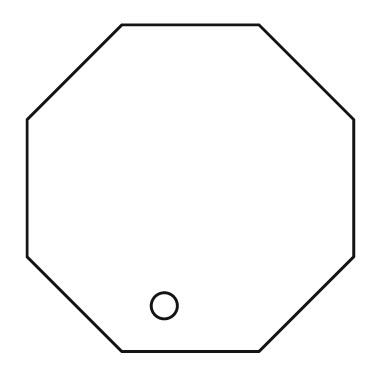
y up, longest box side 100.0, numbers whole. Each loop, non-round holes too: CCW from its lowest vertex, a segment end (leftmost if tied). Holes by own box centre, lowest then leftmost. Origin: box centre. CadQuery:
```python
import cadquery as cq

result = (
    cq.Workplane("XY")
    .moveTo(-21.0, -50.0)
    .lineTo(21.0, -50.0)
    .lineTo(50.0, -21.0)
    .lineTo(50.0, 21.0)
    .lineTo(21.0, 50.0)
    .lineTo(-21.0, 50.0)
    .lineTo(-50.0, 21.0)
    .lineTo(-50.0, -21.0)
    .close()
    .moveTo(-8.0, -36.0)
    .circle(4.0)
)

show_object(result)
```